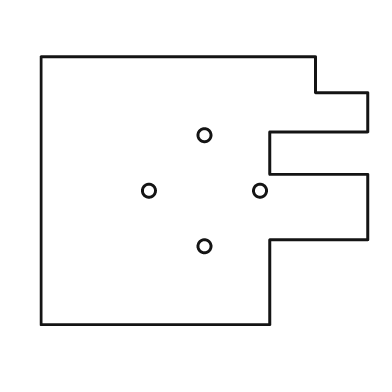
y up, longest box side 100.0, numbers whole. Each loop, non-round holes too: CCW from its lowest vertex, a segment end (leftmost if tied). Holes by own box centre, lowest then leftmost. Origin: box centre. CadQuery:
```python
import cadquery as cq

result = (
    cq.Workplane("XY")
    .moveTo(-50.0, -41.0)
    .lineTo(20.0, -41.0)
    .lineTo(20.0, -15.0)
    .lineTo(50.0, -15.0)
    .lineTo(50.0, 5.0)
    .lineTo(20.0, 5.0)
    .lineTo(20.0, 18.0)
    .lineTo(50.0, 18.0)
    .lineTo(50.0, 30.0)
    .lineTo(34.0, 30.0)
    .lineTo(34.0, 41.0)
    .lineTo(-50.0, 41.0)
    .close()
    .moveTo(0.0, -17.0)
    .circle(2.0)
    .moveTo(-17.0, 0.0)
    .circle(2.0)
    .moveTo(17.0, 0.0)
    .circle(2.0)
    .moveTo(0.0, 17.0)
    .circle(2.0)
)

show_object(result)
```